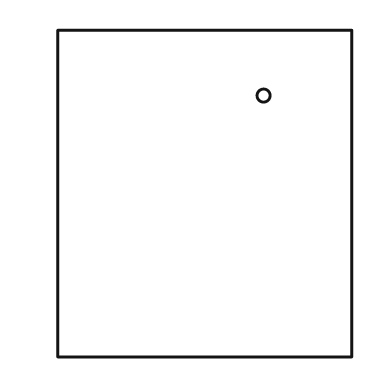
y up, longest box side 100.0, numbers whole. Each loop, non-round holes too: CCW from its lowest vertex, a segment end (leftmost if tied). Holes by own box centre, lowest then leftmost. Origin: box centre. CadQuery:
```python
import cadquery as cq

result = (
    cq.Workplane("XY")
    .moveTo(-45.0, -50.0)
    .lineTo(45.0, -50.0)
    .lineTo(45.0, 50.0)
    .lineTo(-45.0, 50.0)
    .close()
    .moveTo(18.0, 30.0)
    .circle(2.0)
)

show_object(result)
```